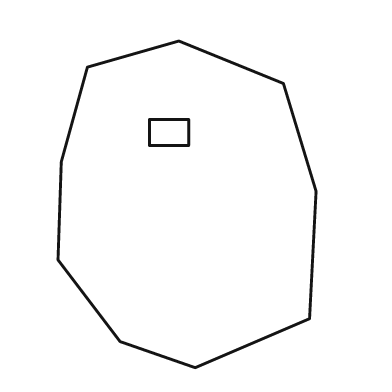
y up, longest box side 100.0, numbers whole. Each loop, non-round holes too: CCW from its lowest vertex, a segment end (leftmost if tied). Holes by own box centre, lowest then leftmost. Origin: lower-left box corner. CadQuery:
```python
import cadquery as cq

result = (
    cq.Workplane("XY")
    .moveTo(42.0, 0.0)
    .lineTo(77.0, 15.0)
    .lineTo(79.0, 54.0)
    .lineTo(69.0, 87.0)
    .lineTo(37.0, 100.0)
    .lineTo(9.0, 92.0)
    .lineTo(1.0, 63.0)
    .lineTo(0.0, 33.0)
    .lineTo(19.0, 8.0)
    .close()
    .moveTo(28.0, 68.0)
    .lineTo(40.0, 68.0)
    .lineTo(40.0, 76.0)
    .lineTo(28.0, 76.0)
    .close()
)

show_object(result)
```